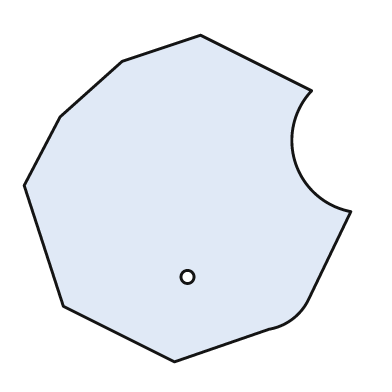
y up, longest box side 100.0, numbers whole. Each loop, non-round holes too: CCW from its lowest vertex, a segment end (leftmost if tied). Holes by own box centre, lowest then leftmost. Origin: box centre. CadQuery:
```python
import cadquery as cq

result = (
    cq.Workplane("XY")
    .moveTo(-4.0, -50.0)
    .lineTo(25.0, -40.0)
    .threePointArc((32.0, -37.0), (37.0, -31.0))
    .lineTo(50.0, -4.0)
    .threePointArc((33.0, 11.0), (38.0, 33.0))
    .lineTo(4.0, 50.0)
    .lineTo(-20.0, 42.0)
    .lineTo(-39.0, 25.0)
    .lineTo(-50.0, 4.0)
    .lineTo(-38.0, -33.0)
    .close()
    .moveTo(0.0, -24.0)
    .circle(2.0)
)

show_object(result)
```